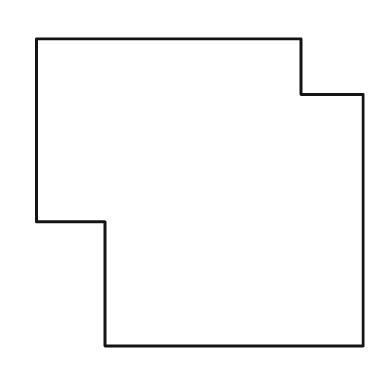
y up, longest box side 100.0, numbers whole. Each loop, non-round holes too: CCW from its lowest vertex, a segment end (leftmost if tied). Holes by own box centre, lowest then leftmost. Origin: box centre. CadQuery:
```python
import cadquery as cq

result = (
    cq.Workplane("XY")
    .moveTo(-29.0, -47.0)
    .lineTo(50.0, -47.0)
    .lineTo(50.0, 30.0)
    .lineTo(31.0, 30.0)
    .lineTo(31.0, 47.0)
    .lineTo(-50.0, 47.0)
    .lineTo(-50.0, -9.0)
    .lineTo(-29.0, -9.0)
    .close()
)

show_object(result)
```